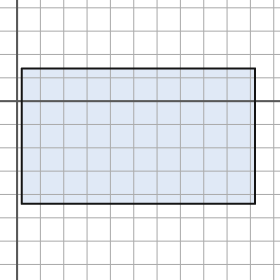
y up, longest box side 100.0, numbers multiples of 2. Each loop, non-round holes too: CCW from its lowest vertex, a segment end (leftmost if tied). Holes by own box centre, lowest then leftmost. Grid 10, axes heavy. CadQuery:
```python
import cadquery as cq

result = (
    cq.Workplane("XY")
    .moveTo(2.0, -44.0)
    .lineTo(102.0, -44.0)
    .lineTo(102.0, 14.0)
    .lineTo(2.0, 14.0)
    .close()
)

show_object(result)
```